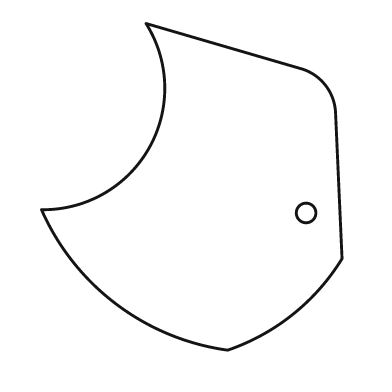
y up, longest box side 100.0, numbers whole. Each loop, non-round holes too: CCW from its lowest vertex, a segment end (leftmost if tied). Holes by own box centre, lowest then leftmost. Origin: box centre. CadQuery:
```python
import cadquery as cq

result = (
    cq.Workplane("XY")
    .moveTo(11.0, -50.0)
    .threePointArc((31.0, -39.0), (46.0, -22.0))
    .lineTo(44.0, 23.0)
    .threePointArc((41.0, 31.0), (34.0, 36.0))
    .lineTo(-14.0, 50.0)
    .threePointArc((-13.0, 12.0), (-46.0, -7.0))
    .threePointArc((-23.0, -36.0), (11.0, -50.0))
    .close()
    .moveTo(35.0, -8.0)
    .circle(3.0)
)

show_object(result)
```